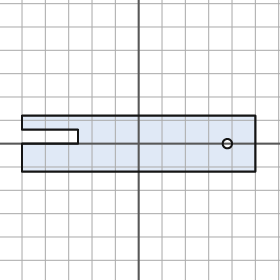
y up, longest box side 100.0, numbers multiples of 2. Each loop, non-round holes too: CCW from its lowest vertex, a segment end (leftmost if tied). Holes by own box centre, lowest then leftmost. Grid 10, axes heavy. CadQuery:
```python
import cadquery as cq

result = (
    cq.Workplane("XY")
    .moveTo(-50.0, -12.0)
    .lineTo(50.0, -12.0)
    .lineTo(50.0, 12.0)
    .lineTo(-50.0, 12.0)
    .lineTo(-50.0, 6.0)
    .lineTo(-26.0, 6.0)
    .lineTo(-26.0, 0.0)
    .lineTo(-50.0, 0.0)
    .close()
    .moveTo(38.0, 0.0)
    .circle(2.0)
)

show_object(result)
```